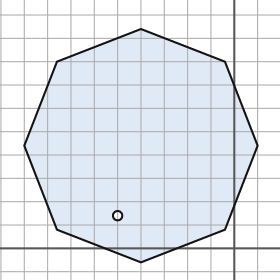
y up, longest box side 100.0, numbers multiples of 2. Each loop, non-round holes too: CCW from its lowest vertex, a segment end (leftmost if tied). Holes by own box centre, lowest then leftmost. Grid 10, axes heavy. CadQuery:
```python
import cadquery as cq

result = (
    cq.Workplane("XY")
    .moveTo(-40.0, -6.0)
    .lineTo(-4.0, 8.0)
    .lineTo(10.0, 44.0)
    .lineTo(-4.0, 80.0)
    .lineTo(-40.0, 94.0)
    .lineTo(-76.0, 80.0)
    .lineTo(-90.0, 44.0)
    .lineTo(-76.0, 8.0)
    .close()
    .moveTo(-50.0, 14.0)
    .circle(2.0)
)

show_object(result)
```